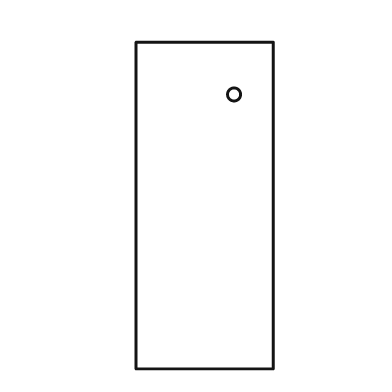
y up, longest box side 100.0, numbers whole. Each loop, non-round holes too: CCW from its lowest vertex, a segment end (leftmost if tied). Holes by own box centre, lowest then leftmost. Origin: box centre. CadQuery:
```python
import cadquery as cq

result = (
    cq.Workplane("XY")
    .moveTo(-21.0, -50.0)
    .lineTo(21.0, -50.0)
    .lineTo(21.0, 50.0)
    .lineTo(-21.0, 50.0)
    .close()
    .moveTo(9.0, 34.0)
    .circle(2.0)
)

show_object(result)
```